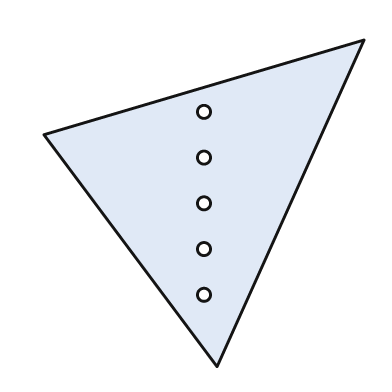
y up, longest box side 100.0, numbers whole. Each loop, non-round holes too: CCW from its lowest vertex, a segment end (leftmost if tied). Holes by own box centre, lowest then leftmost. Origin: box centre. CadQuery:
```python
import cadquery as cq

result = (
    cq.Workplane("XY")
    .moveTo(4.0, -50.0)
    .lineTo(49.0, 50.0)
    .lineTo(-49.0, 21.0)
    .close()
    .moveTo(0.0, -28.0)
    .circle(2.0)
    .moveTo(0.0, -14.0)
    .circle(2.0)
    .moveTo(0.0, 0.0)
    .circle(2.0)
    .moveTo(0.0, 14.0)
    .circle(2.0)
    .moveTo(0.0, 28.0)
    .circle(2.0)
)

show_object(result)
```